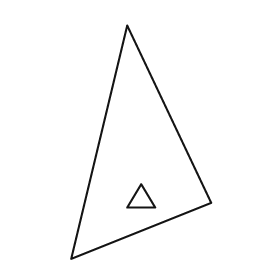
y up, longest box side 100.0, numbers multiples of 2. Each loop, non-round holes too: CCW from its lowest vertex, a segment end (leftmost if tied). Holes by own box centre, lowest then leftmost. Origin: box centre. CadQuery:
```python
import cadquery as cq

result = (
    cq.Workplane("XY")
    .moveTo(-30.0, -50.0)
    .lineTo(30.0, -26.0)
    .lineTo(-6.0, 50.0)
    .close()
    .moveTo(-6.0, -28.0)
    .lineTo(6.0, -28.0)
    .lineTo(0.0, -18.0)
    .close()
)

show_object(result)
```